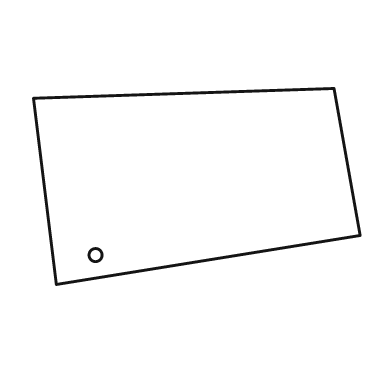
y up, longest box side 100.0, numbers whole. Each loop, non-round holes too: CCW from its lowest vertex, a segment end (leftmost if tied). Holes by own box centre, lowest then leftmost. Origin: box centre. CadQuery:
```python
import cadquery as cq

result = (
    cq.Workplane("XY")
    .moveTo(-43.0, -30.0)
    .lineTo(50.0, -15.0)
    .lineTo(42.0, 30.0)
    .lineTo(-50.0, 27.0)
    .close()
    .moveTo(-31.0, -21.0)
    .circle(2.0)
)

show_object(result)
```